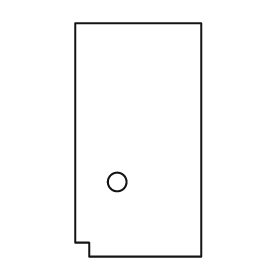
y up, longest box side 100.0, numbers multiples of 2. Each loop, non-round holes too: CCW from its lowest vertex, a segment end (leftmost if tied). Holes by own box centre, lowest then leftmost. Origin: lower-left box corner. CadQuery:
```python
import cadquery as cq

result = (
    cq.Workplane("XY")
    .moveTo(6.0, 0.0)
    .lineTo(54.0, 0.0)
    .lineTo(54.0, 100.0)
    .lineTo(0.0, 100.0)
    .lineTo(0.0, 6.0)
    .lineTo(6.0, 6.0)
    .close()
    .moveTo(18.0, 32.0)
    .circle(4.0)
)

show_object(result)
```